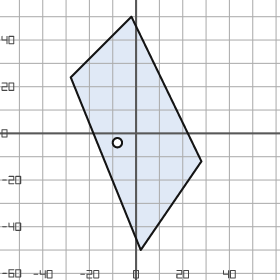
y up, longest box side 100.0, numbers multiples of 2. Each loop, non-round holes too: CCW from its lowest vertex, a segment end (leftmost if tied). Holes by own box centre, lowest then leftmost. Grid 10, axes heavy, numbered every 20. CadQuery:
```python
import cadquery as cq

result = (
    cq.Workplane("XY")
    .moveTo(2.0, -50.0)
    .lineTo(28.0, -12.0)
    .lineTo(-2.0, 50.0)
    .lineTo(-28.0, 24.0)
    .close()
    .moveTo(-8.0, -4.0)
    .circle(2.0)
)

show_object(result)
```